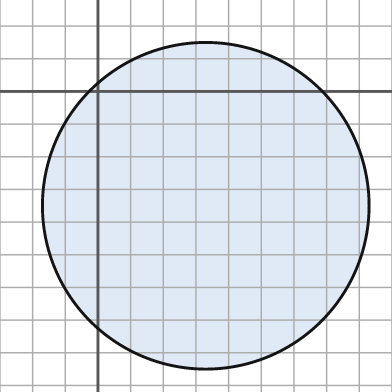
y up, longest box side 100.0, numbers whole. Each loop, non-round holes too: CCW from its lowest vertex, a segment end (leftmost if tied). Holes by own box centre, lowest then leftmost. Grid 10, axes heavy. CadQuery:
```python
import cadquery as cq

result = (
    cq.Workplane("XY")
    .moveTo(33.0, -35.0)
    .circle(50.0)
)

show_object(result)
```